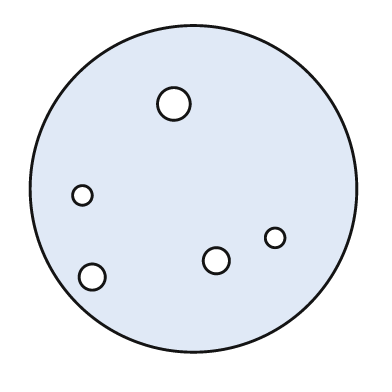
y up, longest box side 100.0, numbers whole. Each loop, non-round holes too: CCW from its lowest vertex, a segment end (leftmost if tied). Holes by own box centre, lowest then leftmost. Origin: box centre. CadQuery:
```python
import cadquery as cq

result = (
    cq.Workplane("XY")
    .moveTo(0.0, 0.0)
    .circle(50.0)
    .moveTo(-31.0, -27.0)
    .circle(4.0)
    .moveTo(7.0, -22.0)
    .circle(4.0)
    .moveTo(25.0, -15.0)
    .circle(3.0)
    .moveTo(-34.0, -2.0)
    .circle(3.0)
    .moveTo(-6.0, 26.0)
    .circle(5.0)
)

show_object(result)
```